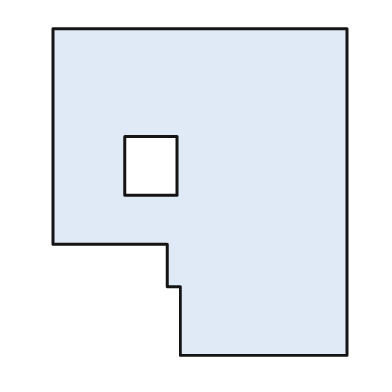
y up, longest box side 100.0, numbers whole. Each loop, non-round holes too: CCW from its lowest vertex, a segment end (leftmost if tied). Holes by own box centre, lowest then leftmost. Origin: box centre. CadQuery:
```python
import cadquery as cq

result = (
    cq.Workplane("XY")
    .moveTo(-6.0, -50.0)
    .lineTo(45.0, -50.0)
    .lineTo(45.0, 50.0)
    .lineTo(-45.0, 50.0)
    .lineTo(-45.0, -16.0)
    .lineTo(-10.0, -16.0)
    .lineTo(-10.0, -29.0)
    .lineTo(-6.0, -29.0)
    .close()
    .moveTo(-23.0, -1.0)
    .lineTo(-7.0, -1.0)
    .lineTo(-7.0, 17.0)
    .lineTo(-23.0, 17.0)
    .close()
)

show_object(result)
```